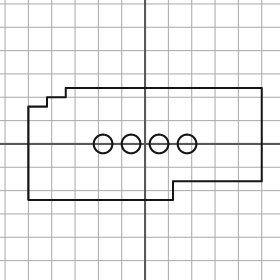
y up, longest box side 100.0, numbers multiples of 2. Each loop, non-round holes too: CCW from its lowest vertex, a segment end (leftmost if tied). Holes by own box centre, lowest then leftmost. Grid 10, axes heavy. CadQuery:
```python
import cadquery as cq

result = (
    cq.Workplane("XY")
    .moveTo(-50.0, -24.0)
    .lineTo(12.0, -24.0)
    .lineTo(12.0, -16.0)
    .lineTo(50.0, -16.0)
    .lineTo(50.0, 24.0)
    .lineTo(-34.0, 24.0)
    .lineTo(-34.0, 20.0)
    .lineTo(-42.0, 20.0)
    .lineTo(-42.0, 16.0)
    .lineTo(-50.0, 16.0)
    .close()
    .moveTo(-18.0, 0.0)
    .circle(4.0)
    .moveTo(-6.0, 0.0)
    .circle(4.0)
    .moveTo(6.0, 0.0)
    .circle(4.0)
    .moveTo(18.0, 0.0)
    .circle(4.0)
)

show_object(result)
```